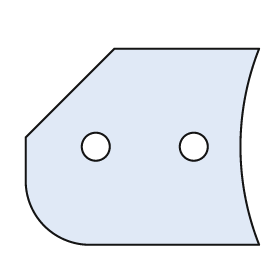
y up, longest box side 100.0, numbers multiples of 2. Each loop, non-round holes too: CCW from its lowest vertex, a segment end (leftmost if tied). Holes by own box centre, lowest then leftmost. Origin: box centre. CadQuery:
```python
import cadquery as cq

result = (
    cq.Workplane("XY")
    .moveTo(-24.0, -42.0)
    .lineTo(50.0, -42.0)
    .threePointArc((42.0, 0.0), (50.0, 42.0))
    .lineTo(-12.0, 42.0)
    .lineTo(-50.0, 4.0)
    .lineTo(-50.0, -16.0)
    .threePointArc((-42.0, -34.0), (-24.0, -42.0))
    .close()
    .moveTo(-20.0, 0.0)
    .circle(6.0)
    .moveTo(22.0, 0.0)
    .circle(6.0)
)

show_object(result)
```